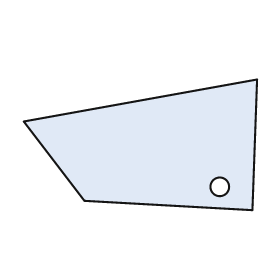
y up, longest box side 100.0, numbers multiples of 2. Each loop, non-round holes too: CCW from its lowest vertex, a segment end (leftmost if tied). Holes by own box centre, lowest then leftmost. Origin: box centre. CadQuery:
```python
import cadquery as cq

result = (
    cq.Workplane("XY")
    .moveTo(48.0, -28.0)
    .lineTo(50.0, 28.0)
    .lineTo(-50.0, 10.0)
    .lineTo(-24.0, -24.0)
    .close()
    .moveTo(34.0, -18.0)
    .circle(4.0)
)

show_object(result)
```